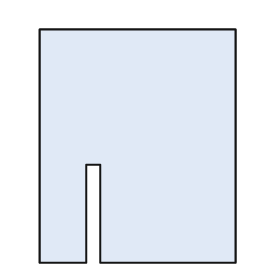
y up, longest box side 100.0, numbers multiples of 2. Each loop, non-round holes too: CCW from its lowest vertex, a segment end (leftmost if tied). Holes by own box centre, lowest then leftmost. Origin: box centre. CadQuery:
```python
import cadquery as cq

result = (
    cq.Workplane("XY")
    .moveTo(-42.0, -50.0)
    .lineTo(-22.0, -50.0)
    .lineTo(-22.0, -8.0)
    .lineTo(-16.0, -8.0)
    .lineTo(-16.0, -50.0)
    .lineTo(42.0, -50.0)
    .lineTo(42.0, 50.0)
    .lineTo(-42.0, 50.0)
    .close()
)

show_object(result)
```